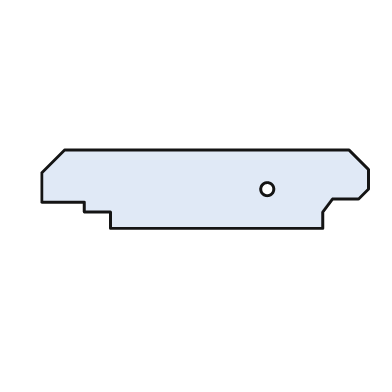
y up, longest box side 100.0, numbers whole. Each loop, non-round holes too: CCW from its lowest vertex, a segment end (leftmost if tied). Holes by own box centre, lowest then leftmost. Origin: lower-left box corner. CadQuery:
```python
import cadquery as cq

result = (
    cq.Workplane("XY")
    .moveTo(21.0, 0.0)
    .lineTo(86.0, 0.0)
    .lineTo(86.0, 5.0)
    .lineTo(89.0, 9.0)
    .lineTo(97.0, 9.0)
    .lineTo(100.0, 12.0)
    .lineTo(100.0, 18.0)
    .lineTo(94.0, 24.0)
    .lineTo(7.0, 24.0)
    .lineTo(0.0, 17.0)
    .lineTo(0.0, 8.0)
    .lineTo(13.0, 8.0)
    .lineTo(13.0, 5.0)
    .lineTo(21.0, 5.0)
    .close()
    .moveTo(69.0, 12.0)
    .circle(2.0)
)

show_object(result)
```